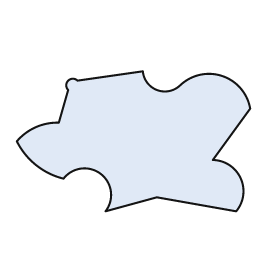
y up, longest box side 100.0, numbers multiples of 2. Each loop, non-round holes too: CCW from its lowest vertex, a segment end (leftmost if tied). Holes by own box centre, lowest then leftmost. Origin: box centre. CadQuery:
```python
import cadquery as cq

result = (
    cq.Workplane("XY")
    .moveTo(-12.0, -30.0)
    .lineTo(10.0, -24.0)
    .lineTo(44.0, -30.0)
    .threePointArc((46.0, -16.0), (34.0, -8.0))
    .lineTo(50.0, 14.0)
    .threePointArc((38.0, 28.0), (20.0, 24.0))
    .threePointArc((10.0, 22.0), (4.0, 30.0))
    .lineTo(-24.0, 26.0)
    .threePointArc((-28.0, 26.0), (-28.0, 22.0))
    .lineTo(-32.0, 8.0)
    .threePointArc((-42.0, 6.0), (-50.0, 0.0))
    .threePointArc((-42.0, -10.0), (-30.0, -16.0))
    .threePointArc((-14.0, -14.0), (-12.0, -30.0))
    .close()
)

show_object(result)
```